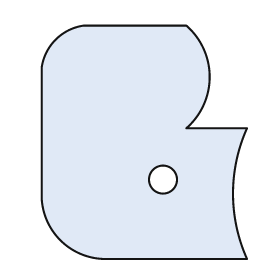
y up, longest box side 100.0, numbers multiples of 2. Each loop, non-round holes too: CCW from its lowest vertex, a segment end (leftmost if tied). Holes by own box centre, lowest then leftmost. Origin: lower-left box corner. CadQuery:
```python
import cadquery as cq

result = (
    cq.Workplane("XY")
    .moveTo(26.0, 0.0)
    .lineTo(88.0, 0.0)
    .threePointArc((82.0, 28.0), (88.0, 56.0))
    .lineTo(62.0, 56.0)
    .threePointArc((72.0, 78.0), (62.0, 100.0))
    .lineTo(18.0, 100.0)
    .threePointArc((6.0, 94.0), (0.0, 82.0))
    .lineTo(0.0, 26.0)
    .threePointArc((8.0, 8.0), (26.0, 0.0))
    .close()
    .moveTo(52.0, 34.0)
    .circle(6.0)
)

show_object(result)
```